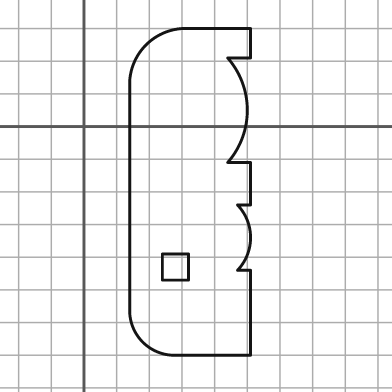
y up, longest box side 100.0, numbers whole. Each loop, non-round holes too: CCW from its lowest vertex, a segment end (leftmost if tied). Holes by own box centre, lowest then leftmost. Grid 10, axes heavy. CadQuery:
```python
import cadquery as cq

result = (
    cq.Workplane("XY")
    .moveTo(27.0, -70.0)
    .lineTo(51.0, -70.0)
    .lineTo(51.0, -44.0)
    .lineTo(47.0, -44.0)
    .threePointArc((51.0, -34.0), (47.0, -24.0))
    .lineTo(51.0, -24.0)
    .lineTo(51.0, -11.0)
    .lineTo(44.0, -11.0)
    .threePointArc((50.0, 5.0), (44.0, 21.0))
    .lineTo(51.0, 21.0)
    .lineTo(51.0, 30.0)
    .lineTo(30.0, 30.0)
    .threePointArc((19.0, 25.0), (14.0, 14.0))
    .lineTo(14.0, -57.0)
    .threePointArc((18.0, -66.0), (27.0, -70.0))
    .close()
    .moveTo(24.0, -47.0)
    .lineTo(32.0, -47.0)
    .lineTo(32.0, -39.0)
    .lineTo(24.0, -39.0)
    .close()
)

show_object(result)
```